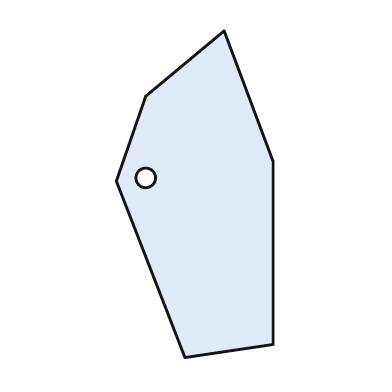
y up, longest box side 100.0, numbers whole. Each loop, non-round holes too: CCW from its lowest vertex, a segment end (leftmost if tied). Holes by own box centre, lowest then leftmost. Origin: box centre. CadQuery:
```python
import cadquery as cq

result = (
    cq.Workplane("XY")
    .moveTo(-3.0, -50.0)
    .lineTo(24.0, -46.0)
    .lineTo(24.0, 10.0)
    .lineTo(9.0, 50.0)
    .lineTo(-15.0, 30.0)
    .lineTo(-24.0, 4.0)
    .close()
    .moveTo(-15.0, 5.0)
    .circle(3.0)
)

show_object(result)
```